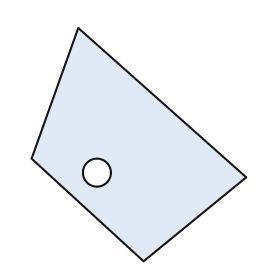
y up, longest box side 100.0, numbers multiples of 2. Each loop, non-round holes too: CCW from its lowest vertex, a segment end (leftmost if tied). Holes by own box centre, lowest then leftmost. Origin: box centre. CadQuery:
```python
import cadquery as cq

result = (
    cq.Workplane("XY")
    .moveTo(2.0, -50.0)
    .lineTo(46.0, -14.0)
    .lineTo(-26.0, 50.0)
    .lineTo(-46.0, -6.0)
    .close()
    .moveTo(-18.0, -12.0)
    .circle(6.0)
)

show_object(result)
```